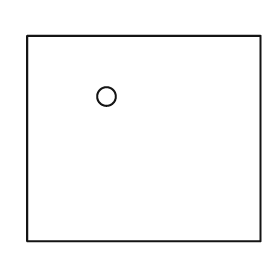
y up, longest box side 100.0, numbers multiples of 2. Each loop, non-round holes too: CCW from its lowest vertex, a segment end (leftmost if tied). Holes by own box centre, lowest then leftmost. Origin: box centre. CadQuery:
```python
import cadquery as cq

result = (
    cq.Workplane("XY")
    .moveTo(-50.0, -44.0)
    .lineTo(50.0, -44.0)
    .lineTo(50.0, 44.0)
    .lineTo(-50.0, 44.0)
    .close()
    .moveTo(-16.0, 18.0)
    .circle(4.0)
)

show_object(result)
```